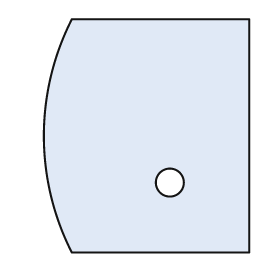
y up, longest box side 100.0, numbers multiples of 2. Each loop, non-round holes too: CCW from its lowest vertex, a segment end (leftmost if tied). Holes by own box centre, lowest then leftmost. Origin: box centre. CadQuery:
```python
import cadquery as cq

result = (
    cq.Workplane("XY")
    .moveTo(-32.0, -50.0)
    .lineTo(44.0, -50.0)
    .lineTo(44.0, 50.0)
    .lineTo(-32.0, 50.0)
    .threePointArc((-44.0, 0.0), (-32.0, -50.0))
    .close()
    .moveTo(10.0, -20.0)
    .circle(6.0)
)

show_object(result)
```